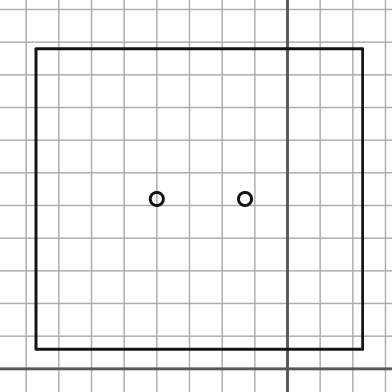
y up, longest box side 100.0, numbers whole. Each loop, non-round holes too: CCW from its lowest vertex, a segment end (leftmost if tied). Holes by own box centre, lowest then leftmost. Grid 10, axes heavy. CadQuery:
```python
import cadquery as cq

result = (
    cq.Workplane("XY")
    .moveTo(-77.0, 6.0)
    .lineTo(23.0, 6.0)
    .lineTo(23.0, 98.0)
    .lineTo(-77.0, 98.0)
    .close()
    .moveTo(-40.0, 52.0)
    .circle(2.0)
    .moveTo(-13.0, 52.0)
    .circle(2.0)
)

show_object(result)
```